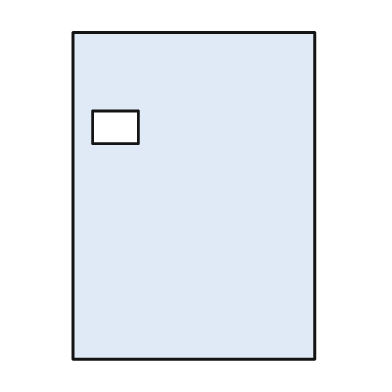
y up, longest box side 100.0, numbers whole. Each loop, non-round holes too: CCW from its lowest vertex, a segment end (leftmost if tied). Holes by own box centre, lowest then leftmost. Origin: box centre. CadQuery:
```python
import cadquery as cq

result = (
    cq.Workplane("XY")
    .moveTo(-37.0, -50.0)
    .lineTo(37.0, -50.0)
    .lineTo(37.0, 50.0)
    .lineTo(-37.0, 50.0)
    .close()
    .moveTo(-31.0, 16.0)
    .lineTo(-17.0, 16.0)
    .lineTo(-17.0, 26.0)
    .lineTo(-31.0, 26.0)
    .close()
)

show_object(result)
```